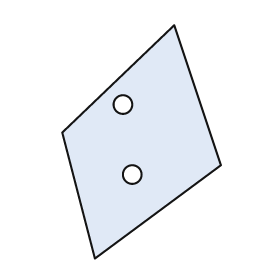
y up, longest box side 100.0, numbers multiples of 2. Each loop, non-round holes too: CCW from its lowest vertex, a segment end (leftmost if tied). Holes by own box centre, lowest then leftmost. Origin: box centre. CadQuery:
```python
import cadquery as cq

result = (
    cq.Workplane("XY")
    .moveTo(-20.0, -50.0)
    .lineTo(34.0, -10.0)
    .lineTo(14.0, 50.0)
    .lineTo(-34.0, 4.0)
    .close()
    .moveTo(-4.0, -14.0)
    .circle(4.0)
    .moveTo(-8.0, 16.0)
    .circle(4.0)
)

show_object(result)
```